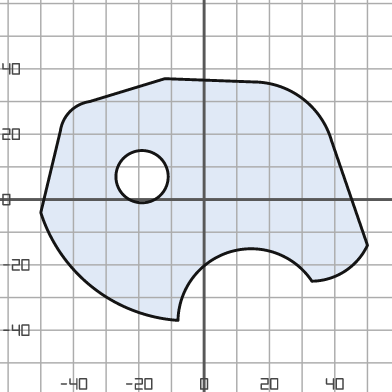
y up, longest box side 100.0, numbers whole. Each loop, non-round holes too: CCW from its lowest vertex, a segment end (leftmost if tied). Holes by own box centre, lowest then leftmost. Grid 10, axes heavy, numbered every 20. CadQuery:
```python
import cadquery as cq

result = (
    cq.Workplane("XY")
    .moveTo(-8.0, -37.0)
    .threePointArc((8.0, -16.0), (33.0, -25.0))
    .threePointArc((43.0, -22.0), (50.0, -14.0))
    .lineTo(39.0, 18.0)
    .threePointArc((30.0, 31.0), (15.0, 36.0))
    .lineTo(-12.0, 37.0)
    .lineTo(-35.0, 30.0)
    .threePointArc((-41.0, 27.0), (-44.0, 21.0))
    .lineTo(-50.0, -4.0)
    .threePointArc((-34.0, -27.0), (-8.0, -37.0))
    .close()
    .moveTo(-19.0, 7.0)
    .circle(8.0)
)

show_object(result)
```